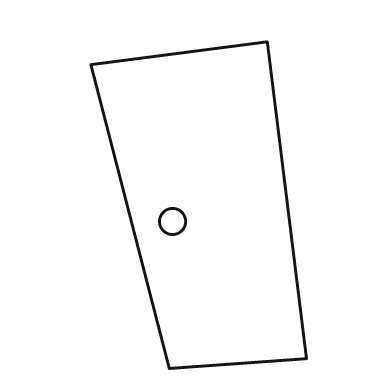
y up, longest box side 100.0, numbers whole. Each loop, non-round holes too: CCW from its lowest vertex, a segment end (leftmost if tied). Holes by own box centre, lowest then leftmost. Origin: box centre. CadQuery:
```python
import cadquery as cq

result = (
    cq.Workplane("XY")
    .moveTo(-9.0, -50.0)
    .lineTo(33.0, -47.0)
    .lineTo(21.0, 50.0)
    .lineTo(-33.0, 43.0)
    .close()
    .moveTo(-8.0, -5.0)
    .circle(4.0)
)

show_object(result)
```